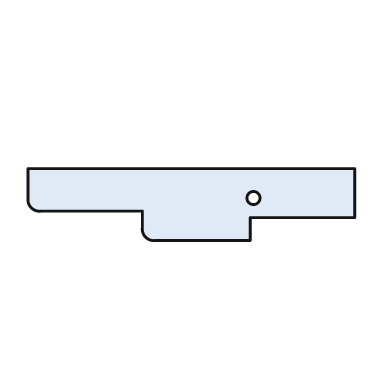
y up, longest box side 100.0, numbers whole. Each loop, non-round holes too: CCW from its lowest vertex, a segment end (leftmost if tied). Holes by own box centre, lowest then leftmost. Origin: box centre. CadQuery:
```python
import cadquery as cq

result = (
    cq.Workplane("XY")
    .moveTo(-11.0, -11.0)
    .lineTo(18.0, -11.0)
    .lineTo(18.0, -4.0)
    .lineTo(50.0, -4.0)
    .lineTo(50.0, 11.0)
    .lineTo(-50.0, 11.0)
    .lineTo(-50.0, 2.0)
    .threePointArc((-49.0, -1.0), (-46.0, -2.0))
    .lineTo(-15.0, -2.0)
    .lineTo(-15.0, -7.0)
    .threePointArc((-14.0, -10.0), (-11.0, -11.0))
    .close()
    .moveTo(19.0, 2.0)
    .circle(2.0)
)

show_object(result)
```